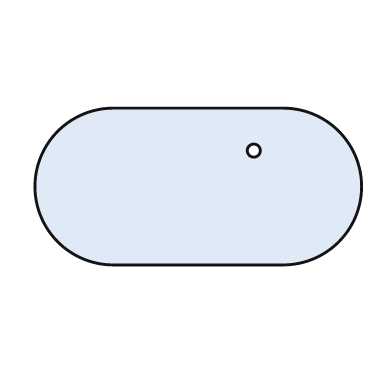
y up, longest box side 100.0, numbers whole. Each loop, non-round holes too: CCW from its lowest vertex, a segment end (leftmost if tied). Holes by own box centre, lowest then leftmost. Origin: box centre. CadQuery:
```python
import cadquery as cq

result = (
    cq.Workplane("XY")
    .moveTo(-26.0, -24.0)
    .lineTo(26.0, -24.0)
    .threePointArc((50.0, 0.0), (26.0, 24.0))
    .lineTo(-26.0, 24.0)
    .threePointArc((-50.0, 0.0), (-26.0, -24.0))
    .close()
    .moveTo(17.0, 11.0)
    .circle(2.0)
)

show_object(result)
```